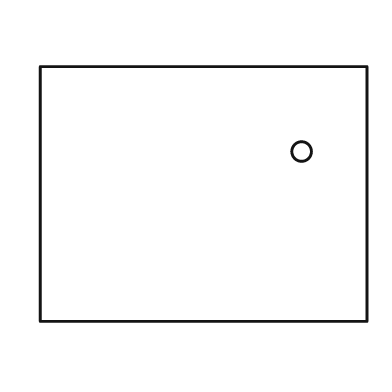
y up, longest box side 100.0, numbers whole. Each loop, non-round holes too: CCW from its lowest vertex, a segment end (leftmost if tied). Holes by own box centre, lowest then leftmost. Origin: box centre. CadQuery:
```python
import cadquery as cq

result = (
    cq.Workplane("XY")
    .moveTo(-50.0, -39.0)
    .lineTo(50.0, -39.0)
    .lineTo(50.0, 39.0)
    .lineTo(-50.0, 39.0)
    .close()
    .moveTo(30.0, 13.0)
    .circle(3.0)
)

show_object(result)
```